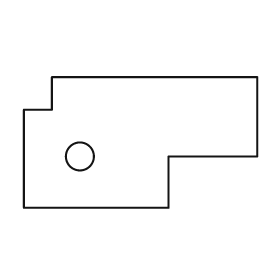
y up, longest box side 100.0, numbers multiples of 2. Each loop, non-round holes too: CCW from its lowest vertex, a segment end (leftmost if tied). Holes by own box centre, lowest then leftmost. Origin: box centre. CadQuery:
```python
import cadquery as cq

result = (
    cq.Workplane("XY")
    .moveTo(-50.0, -28.0)
    .lineTo(12.0, -28.0)
    .lineTo(12.0, -6.0)
    .lineTo(50.0, -6.0)
    .lineTo(50.0, 28.0)
    .lineTo(-38.0, 28.0)
    .lineTo(-38.0, 14.0)
    .lineTo(-50.0, 14.0)
    .close()
    .moveTo(-26.0, -6.0)
    .circle(6.0)
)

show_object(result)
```